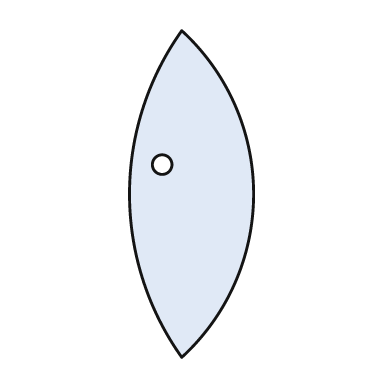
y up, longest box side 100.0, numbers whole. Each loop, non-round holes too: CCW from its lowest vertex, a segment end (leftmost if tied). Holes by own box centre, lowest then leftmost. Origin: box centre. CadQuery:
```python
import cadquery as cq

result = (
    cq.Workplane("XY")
    .moveTo(-3.0, -50.0)
    .threePointArc((19.0, 0.0), (-3.0, 50.0))
    .threePointArc((-19.0, 0.0), (-3.0, -50.0))
    .close()
    .moveTo(-9.0, 9.0)
    .circle(3.0)
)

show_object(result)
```